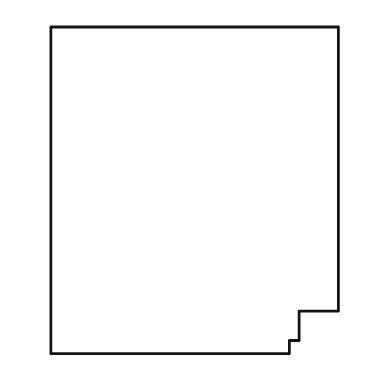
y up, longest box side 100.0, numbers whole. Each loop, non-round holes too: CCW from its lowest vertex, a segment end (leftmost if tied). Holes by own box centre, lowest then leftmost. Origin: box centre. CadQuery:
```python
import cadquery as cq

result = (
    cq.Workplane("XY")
    .moveTo(-44.0, -50.0)
    .lineTo(29.0, -50.0)
    .lineTo(29.0, -46.0)
    .lineTo(32.0, -46.0)
    .lineTo(32.0, -37.0)
    .lineTo(44.0, -37.0)
    .lineTo(44.0, 50.0)
    .lineTo(-44.0, 50.0)
    .close()
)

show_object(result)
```